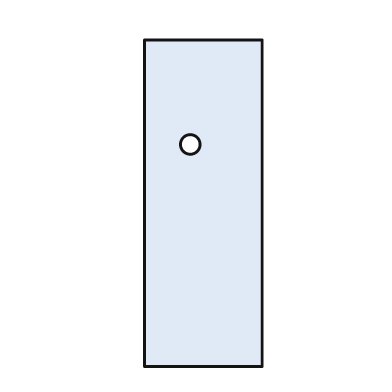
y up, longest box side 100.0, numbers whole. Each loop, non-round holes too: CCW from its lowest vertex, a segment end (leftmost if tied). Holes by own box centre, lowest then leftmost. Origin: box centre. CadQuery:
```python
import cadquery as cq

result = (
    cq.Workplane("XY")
    .moveTo(-18.0, -50.0)
    .lineTo(18.0, -50.0)
    .lineTo(18.0, 50.0)
    .lineTo(-18.0, 50.0)
    .close()
    .moveTo(-4.0, 18.0)
    .circle(3.0)
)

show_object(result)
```